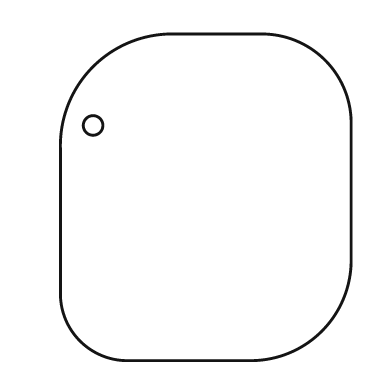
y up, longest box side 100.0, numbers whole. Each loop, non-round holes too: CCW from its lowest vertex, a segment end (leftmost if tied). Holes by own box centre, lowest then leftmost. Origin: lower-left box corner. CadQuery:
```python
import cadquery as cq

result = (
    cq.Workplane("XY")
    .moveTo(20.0, 0.0)
    .lineTo(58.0, 0.0)
    .threePointArc((80.0, 9.0), (89.0, 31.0))
    .lineTo(89.0, 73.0)
    .threePointArc((81.0, 92.0), (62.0, 100.0))
    .lineTo(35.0, 100.0)
    .threePointArc((10.0, 90.0), (0.0, 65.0))
    .lineTo(0.0, 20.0)
    .threePointArc((6.0, 6.0), (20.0, 0.0))
    .close()
    .moveTo(10.0, 72.0)
    .circle(3.0)
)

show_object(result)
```